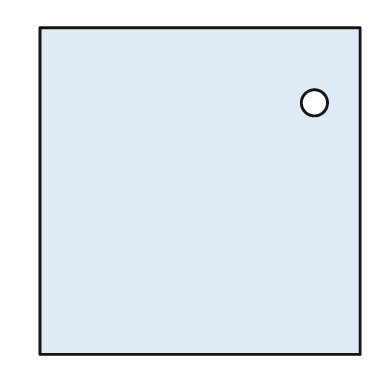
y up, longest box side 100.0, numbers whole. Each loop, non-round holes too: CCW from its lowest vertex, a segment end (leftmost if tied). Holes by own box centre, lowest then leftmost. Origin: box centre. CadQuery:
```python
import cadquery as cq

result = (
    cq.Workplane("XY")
    .moveTo(-49.0, -50.0)
    .lineTo(49.0, -50.0)
    .lineTo(49.0, 50.0)
    .lineTo(-49.0, 50.0)
    .close()
    .moveTo(35.0, 27.0)
    .circle(4.0)
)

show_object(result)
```